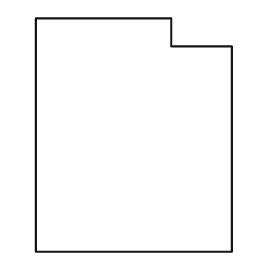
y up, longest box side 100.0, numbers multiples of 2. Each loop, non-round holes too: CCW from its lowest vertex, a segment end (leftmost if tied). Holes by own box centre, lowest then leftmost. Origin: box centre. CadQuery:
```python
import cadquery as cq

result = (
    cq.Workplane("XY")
    .moveTo(-42.0, -50.0)
    .lineTo(42.0, -50.0)
    .lineTo(42.0, 38.0)
    .lineTo(16.0, 38.0)
    .lineTo(16.0, 50.0)
    .lineTo(-42.0, 50.0)
    .close()
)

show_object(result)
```